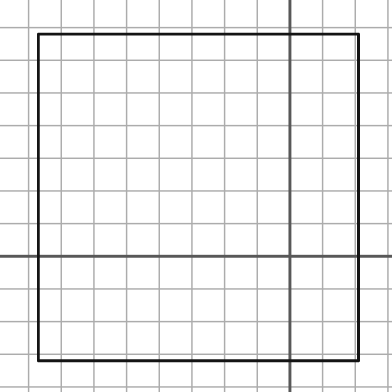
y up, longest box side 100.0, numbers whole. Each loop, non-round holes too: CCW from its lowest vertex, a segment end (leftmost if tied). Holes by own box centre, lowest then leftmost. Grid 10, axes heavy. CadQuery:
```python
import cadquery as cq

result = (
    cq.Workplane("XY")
    .moveTo(-77.0, -32.0)
    .lineTo(21.0, -32.0)
    .lineTo(21.0, 68.0)
    .lineTo(-77.0, 68.0)
    .close()
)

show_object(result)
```